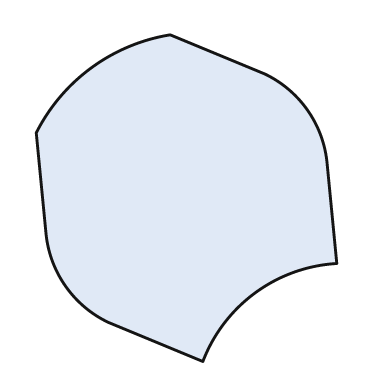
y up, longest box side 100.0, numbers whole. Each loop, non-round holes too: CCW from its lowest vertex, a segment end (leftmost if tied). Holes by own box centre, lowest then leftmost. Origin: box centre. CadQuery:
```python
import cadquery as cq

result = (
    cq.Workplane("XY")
    .moveTo(5.0, -50.0)
    .threePointArc((21.0, -29.0), (46.0, -20.0))
    .lineTo(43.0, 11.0)
    .threePointArc((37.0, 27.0), (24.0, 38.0))
    .lineTo(-5.0, 50.0)
    .threePointArc((-29.0, 40.0), (-46.0, 20.0))
    .lineTo(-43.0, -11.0)
    .threePointArc((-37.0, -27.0), (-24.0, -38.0))
    .close()
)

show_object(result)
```